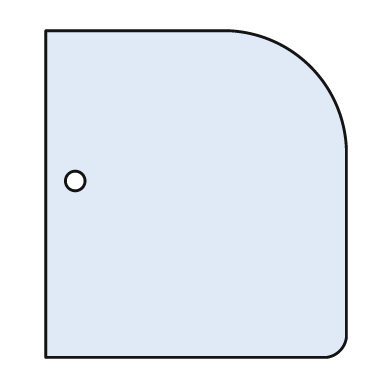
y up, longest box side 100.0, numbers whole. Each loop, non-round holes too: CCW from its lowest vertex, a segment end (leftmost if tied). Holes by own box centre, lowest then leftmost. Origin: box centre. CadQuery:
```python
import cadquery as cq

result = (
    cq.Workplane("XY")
    .moveTo(-46.0, -50.0)
    .lineTo(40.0, -50.0)
    .threePointArc((44.0, -48.0), (46.0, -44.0))
    .lineTo(46.0, 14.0)
    .threePointArc((35.0, 39.0), (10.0, 50.0))
    .lineTo(-46.0, 50.0)
    .close()
    .moveTo(-37.0, 4.0)
    .circle(3.0)
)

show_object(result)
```